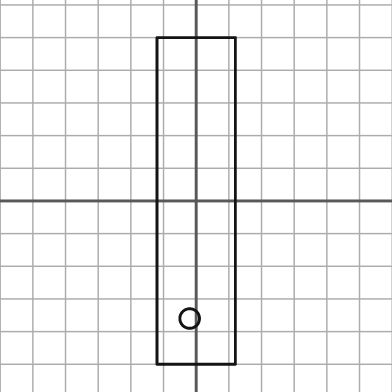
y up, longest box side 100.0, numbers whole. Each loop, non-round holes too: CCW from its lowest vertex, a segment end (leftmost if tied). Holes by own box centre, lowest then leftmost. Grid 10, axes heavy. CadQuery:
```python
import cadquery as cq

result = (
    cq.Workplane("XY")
    .moveTo(-12.0, -50.0)
    .lineTo(12.0, -50.0)
    .lineTo(12.0, 50.0)
    .lineTo(-12.0, 50.0)
    .close()
    .moveTo(-2.0, -36.0)
    .circle(3.0)
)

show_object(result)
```